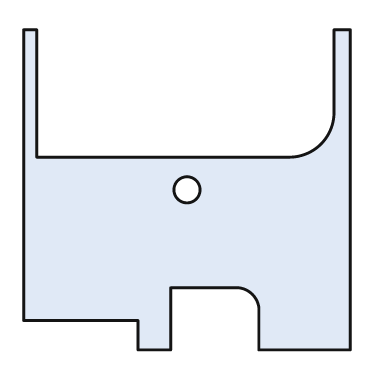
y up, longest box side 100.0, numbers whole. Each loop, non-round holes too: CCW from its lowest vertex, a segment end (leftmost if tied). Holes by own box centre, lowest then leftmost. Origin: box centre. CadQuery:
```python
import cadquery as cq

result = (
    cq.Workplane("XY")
    .moveTo(-15.0, -49.0)
    .lineTo(-5.0, -49.0)
    .lineTo(-5.0, -30.0)
    .lineTo(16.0, -30.0)
    .threePointArc((20.0, -32.0), (22.0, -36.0))
    .lineTo(22.0, -49.0)
    .lineTo(50.0, -49.0)
    .lineTo(50.0, 49.0)
    .lineTo(45.0, 49.0)
    .lineTo(45.0, 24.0)
    .threePointArc((41.0, 14.0), (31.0, 10.0))
    .lineTo(-46.0, 10.0)
    .lineTo(-46.0, 49.0)
    .lineTo(-50.0, 49.0)
    .lineTo(-50.0, -40.0)
    .lineTo(-15.0, -40.0)
    .close()
    .moveTo(0.0, 0.0)
    .circle(4.0)
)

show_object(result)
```